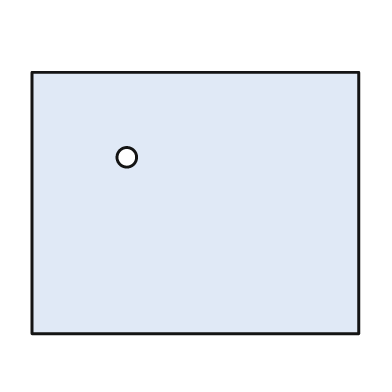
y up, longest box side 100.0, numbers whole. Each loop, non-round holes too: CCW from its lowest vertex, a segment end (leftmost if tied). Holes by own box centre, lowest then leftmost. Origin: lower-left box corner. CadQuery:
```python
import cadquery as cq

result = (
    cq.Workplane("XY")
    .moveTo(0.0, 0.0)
    .lineTo(100.0, 0.0)
    .lineTo(100.0, 80.0)
    .lineTo(0.0, 80.0)
    .close()
    .moveTo(29.0, 54.0)
    .circle(3.0)
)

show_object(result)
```